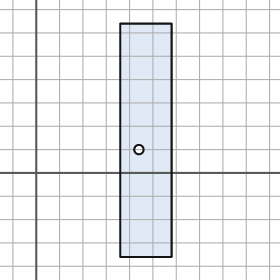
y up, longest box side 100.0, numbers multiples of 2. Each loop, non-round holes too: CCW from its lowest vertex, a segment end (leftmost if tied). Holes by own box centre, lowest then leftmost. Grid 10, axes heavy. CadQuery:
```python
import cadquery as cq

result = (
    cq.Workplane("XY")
    .moveTo(36.0, -36.0)
    .lineTo(58.0, -36.0)
    .lineTo(58.0, 64.0)
    .lineTo(36.0, 64.0)
    .close()
    .moveTo(44.0, 10.0)
    .circle(2.0)
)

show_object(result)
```